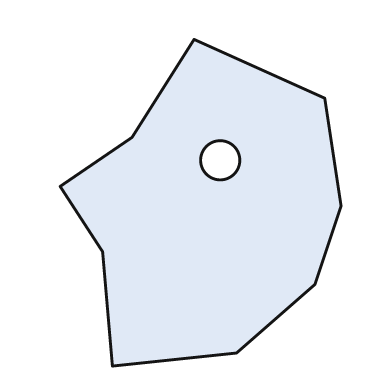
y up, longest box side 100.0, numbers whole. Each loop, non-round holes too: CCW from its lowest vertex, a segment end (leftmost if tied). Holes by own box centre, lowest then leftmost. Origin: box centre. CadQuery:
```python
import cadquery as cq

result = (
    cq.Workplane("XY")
    .moveTo(-27.0, -50.0)
    .lineTo(11.0, -46.0)
    .lineTo(35.0, -25.0)
    .lineTo(43.0, -1.0)
    .lineTo(38.0, 32.0)
    .lineTo(-2.0, 50.0)
    .lineTo(-21.0, 20.0)
    .lineTo(-43.0, 5.0)
    .lineTo(-30.0, -15.0)
    .close()
    .moveTo(6.0, 13.0)
    .circle(6.0)
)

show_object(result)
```